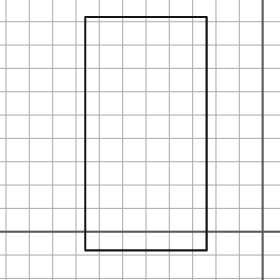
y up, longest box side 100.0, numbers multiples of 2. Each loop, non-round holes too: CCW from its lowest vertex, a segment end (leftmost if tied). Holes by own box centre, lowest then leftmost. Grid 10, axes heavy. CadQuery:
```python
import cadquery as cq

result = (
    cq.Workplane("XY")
    .moveTo(-76.0, -8.0)
    .lineTo(-24.0, -8.0)
    .lineTo(-24.0, 92.0)
    .lineTo(-76.0, 92.0)
    .close()
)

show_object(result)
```